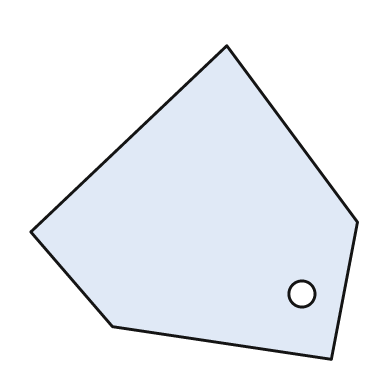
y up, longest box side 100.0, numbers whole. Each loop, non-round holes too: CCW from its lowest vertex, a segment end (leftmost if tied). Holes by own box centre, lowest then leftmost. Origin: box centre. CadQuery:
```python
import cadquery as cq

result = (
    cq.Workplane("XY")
    .moveTo(42.0, -48.0)
    .lineTo(50.0, -6.0)
    .lineTo(10.0, 48.0)
    .lineTo(-50.0, -9.0)
    .lineTo(-25.0, -38.0)
    .close()
    .moveTo(33.0, -28.0)
    .circle(4.0)
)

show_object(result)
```